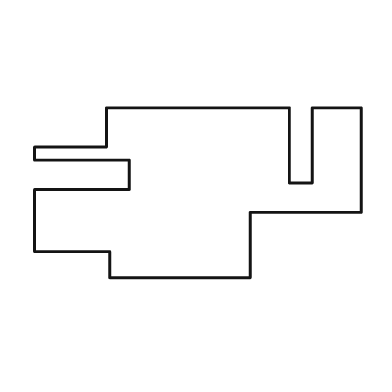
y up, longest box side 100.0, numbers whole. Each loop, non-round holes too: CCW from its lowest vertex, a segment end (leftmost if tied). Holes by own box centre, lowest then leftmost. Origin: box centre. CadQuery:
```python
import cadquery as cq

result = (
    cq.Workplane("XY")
    .moveTo(-27.0, -26.0)
    .lineTo(16.0, -26.0)
    .lineTo(16.0, -6.0)
    .lineTo(50.0, -6.0)
    .lineTo(50.0, 26.0)
    .lineTo(35.0, 26.0)
    .lineTo(35.0, 3.0)
    .lineTo(28.0, 3.0)
    .lineTo(28.0, 26.0)
    .lineTo(-28.0, 26.0)
    .lineTo(-28.0, 14.0)
    .lineTo(-50.0, 14.0)
    .lineTo(-50.0, 10.0)
    .lineTo(-21.0, 10.0)
    .lineTo(-21.0, 1.0)
    .lineTo(-50.0, 1.0)
    .lineTo(-50.0, -18.0)
    .lineTo(-27.0, -18.0)
    .close()
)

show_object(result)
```